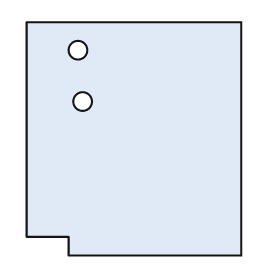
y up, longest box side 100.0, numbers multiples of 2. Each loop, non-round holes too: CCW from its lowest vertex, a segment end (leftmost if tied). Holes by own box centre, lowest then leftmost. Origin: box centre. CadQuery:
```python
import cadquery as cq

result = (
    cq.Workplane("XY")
    .moveTo(-28.0, -50.0)
    .lineTo(46.0, -50.0)
    .lineTo(46.0, 50.0)
    .lineTo(-46.0, 50.0)
    .lineTo(-46.0, -42.0)
    .lineTo(-28.0, -42.0)
    .close()
    .moveTo(-22.0, 16.0)
    .circle(4.0)
    .moveTo(-24.0, 38.0)
    .circle(4.0)
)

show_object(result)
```